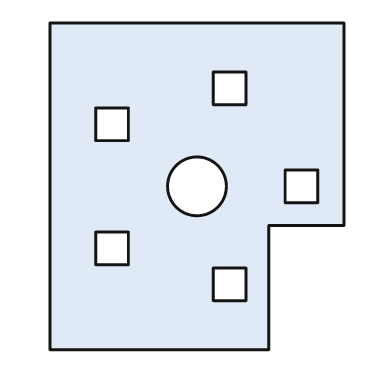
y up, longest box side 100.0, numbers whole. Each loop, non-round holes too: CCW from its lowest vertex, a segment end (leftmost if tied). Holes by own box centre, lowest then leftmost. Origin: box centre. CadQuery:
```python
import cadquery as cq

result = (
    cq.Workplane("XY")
    .moveTo(-45.0, -50.0)
    .lineTo(22.0, -50.0)
    .lineTo(22.0, -12.0)
    .lineTo(45.0, -12.0)
    .lineTo(45.0, 50.0)
    .lineTo(-45.0, 50.0)
    .close()
    .moveTo(5.0, -35.0)
    .lineTo(15.0, -35.0)
    .lineTo(15.0, -25.0)
    .lineTo(5.0, -25.0)
    .close()
    .moveTo(-31.0, -24.0)
    .lineTo(-21.0, -24.0)
    .lineTo(-21.0, -14.0)
    .lineTo(-31.0, -14.0)
    .close()
    .moveTo(0.0, 0.0)
    .circle(9.0)
    .moveTo(27.0, -5.0)
    .lineTo(37.0, -5.0)
    .lineTo(37.0, 5.0)
    .lineTo(27.0, 5.0)
    .close()
    .moveTo(-31.0, 14.0)
    .lineTo(-21.0, 14.0)
    .lineTo(-21.0, 24.0)
    .lineTo(-31.0, 24.0)
    .close()
    .moveTo(5.0, 25.0)
    .lineTo(15.0, 25.0)
    .lineTo(15.0, 35.0)
    .lineTo(5.0, 35.0)
    .close()
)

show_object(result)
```